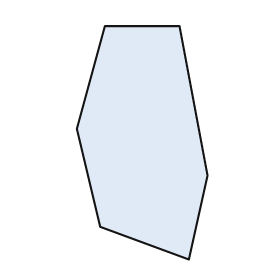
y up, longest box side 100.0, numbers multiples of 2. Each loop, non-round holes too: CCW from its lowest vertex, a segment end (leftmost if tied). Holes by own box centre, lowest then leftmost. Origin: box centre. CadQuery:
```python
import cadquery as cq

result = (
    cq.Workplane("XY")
    .moveTo(20.0, -50.0)
    .lineTo(28.0, -14.0)
    .lineTo(16.0, 50.0)
    .lineTo(-16.0, 50.0)
    .lineTo(-28.0, 6.0)
    .lineTo(-18.0, -36.0)
    .close()
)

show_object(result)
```